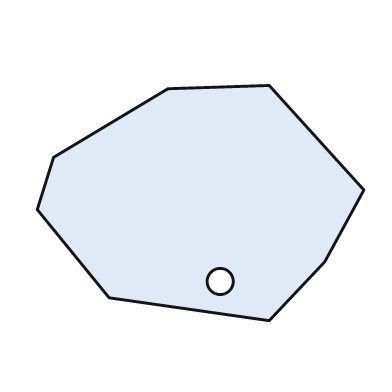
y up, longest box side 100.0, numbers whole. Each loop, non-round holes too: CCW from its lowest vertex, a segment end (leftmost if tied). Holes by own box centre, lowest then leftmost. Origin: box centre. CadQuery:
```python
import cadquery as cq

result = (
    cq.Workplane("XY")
    .moveTo(21.0, -36.0)
    .lineTo(38.0, -18.0)
    .lineTo(50.0, 4.0)
    .lineTo(21.0, 36.0)
    .lineTo(-10.0, 35.0)
    .lineTo(-45.0, 14.0)
    .lineTo(-50.0, -2.0)
    .lineTo(-28.0, -29.0)
    .close()
    .moveTo(6.0, -24.0)
    .circle(4.0)
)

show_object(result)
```